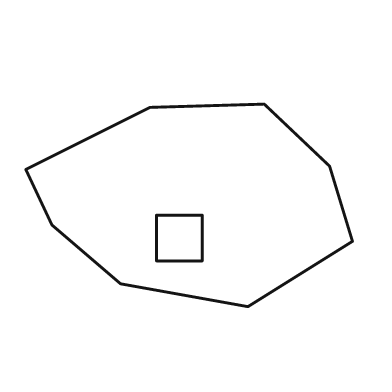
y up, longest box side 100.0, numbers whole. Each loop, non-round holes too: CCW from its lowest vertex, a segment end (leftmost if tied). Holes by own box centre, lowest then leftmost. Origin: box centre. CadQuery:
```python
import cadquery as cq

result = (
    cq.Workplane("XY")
    .moveTo(18.0, -31.0)
    .lineTo(50.0, -11.0)
    .lineTo(43.0, 12.0)
    .lineTo(23.0, 31.0)
    .lineTo(-12.0, 30.0)
    .lineTo(-50.0, 11.0)
    .lineTo(-42.0, -6.0)
    .lineTo(-21.0, -24.0)
    .close()
    .moveTo(-10.0, -17.0)
    .lineTo(4.0, -17.0)
    .lineTo(4.0, -3.0)
    .lineTo(-10.0, -3.0)
    .close()
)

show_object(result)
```